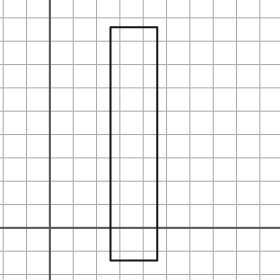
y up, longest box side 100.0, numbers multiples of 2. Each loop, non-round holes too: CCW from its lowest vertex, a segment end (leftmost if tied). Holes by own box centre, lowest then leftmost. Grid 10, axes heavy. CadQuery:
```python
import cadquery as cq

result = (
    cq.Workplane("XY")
    .moveTo(26.0, -14.0)
    .lineTo(46.0, -14.0)
    .lineTo(46.0, 86.0)
    .lineTo(26.0, 86.0)
    .close()
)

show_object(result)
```